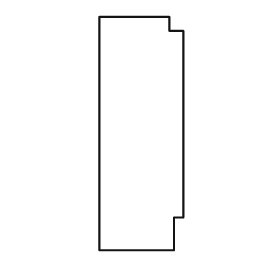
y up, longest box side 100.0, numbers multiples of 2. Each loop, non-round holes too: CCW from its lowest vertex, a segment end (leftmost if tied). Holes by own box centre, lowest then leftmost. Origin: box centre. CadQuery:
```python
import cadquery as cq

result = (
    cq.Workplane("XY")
    .moveTo(-18.0, -50.0)
    .lineTo(14.0, -50.0)
    .lineTo(14.0, -36.0)
    .lineTo(18.0, -36.0)
    .lineTo(18.0, 44.0)
    .lineTo(12.0, 44.0)
    .lineTo(12.0, 50.0)
    .lineTo(-18.0, 50.0)
    .close()
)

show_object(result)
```